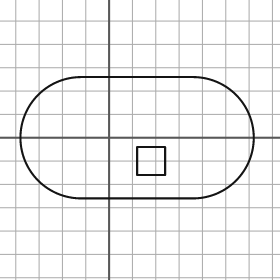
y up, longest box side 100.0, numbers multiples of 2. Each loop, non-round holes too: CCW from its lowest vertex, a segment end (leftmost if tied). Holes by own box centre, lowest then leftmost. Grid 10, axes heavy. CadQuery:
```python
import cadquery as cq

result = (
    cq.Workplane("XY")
    .moveTo(-12.0, -26.0)
    .lineTo(36.0, -26.0)
    .threePointArc((62.0, 0.0), (36.0, 26.0))
    .lineTo(-12.0, 26.0)
    .threePointArc((-38.0, 0.0), (-12.0, -26.0))
    .close()
    .moveTo(12.0, -16.0)
    .lineTo(24.0, -16.0)
    .lineTo(24.0, -4.0)
    .lineTo(12.0, -4.0)
    .close()
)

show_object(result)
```